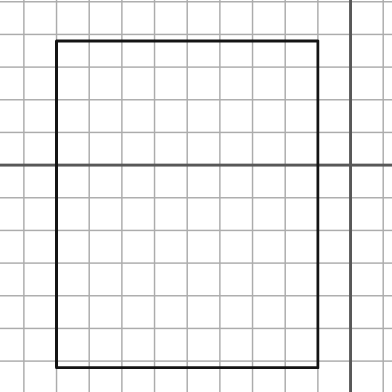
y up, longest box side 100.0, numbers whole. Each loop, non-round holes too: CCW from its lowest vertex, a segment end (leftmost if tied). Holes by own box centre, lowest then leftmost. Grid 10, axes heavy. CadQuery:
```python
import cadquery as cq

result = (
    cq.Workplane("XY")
    .moveTo(-90.0, -62.0)
    .lineTo(-10.0, -62.0)
    .lineTo(-10.0, 38.0)
    .lineTo(-90.0, 38.0)
    .close()
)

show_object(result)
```